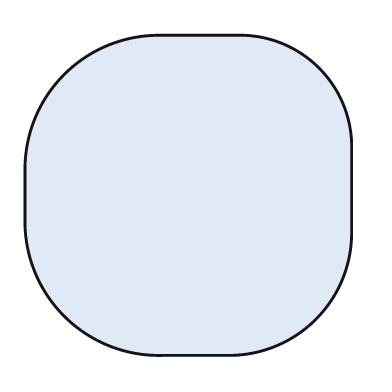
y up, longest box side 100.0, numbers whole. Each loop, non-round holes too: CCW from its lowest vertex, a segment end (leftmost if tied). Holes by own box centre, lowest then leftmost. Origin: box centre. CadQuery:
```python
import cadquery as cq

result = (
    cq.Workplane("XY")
    .moveTo(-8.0, -49.0)
    .lineTo(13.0, -49.0)
    .threePointArc((39.0, -38.0), (50.0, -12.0))
    .lineTo(50.0, 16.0)
    .threePointArc((40.0, 39.0), (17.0, 49.0))
    .lineTo(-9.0, 49.0)
    .threePointArc((-38.0, 37.0), (-50.0, 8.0))
    .lineTo(-50.0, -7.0)
    .threePointArc((-38.0, -37.0), (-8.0, -49.0))
    .close()
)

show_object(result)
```